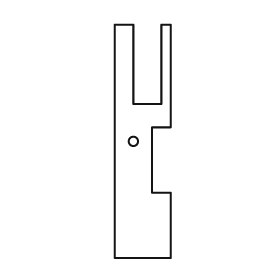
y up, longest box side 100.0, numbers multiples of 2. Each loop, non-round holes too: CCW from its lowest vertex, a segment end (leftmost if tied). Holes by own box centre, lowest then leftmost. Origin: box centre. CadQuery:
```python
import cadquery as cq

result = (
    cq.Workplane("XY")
    .moveTo(-12.0, -50.0)
    .lineTo(12.0, -50.0)
    .lineTo(12.0, -22.0)
    .lineTo(4.0, -22.0)
    .lineTo(4.0, 6.0)
    .lineTo(12.0, 6.0)
    .lineTo(12.0, 50.0)
    .lineTo(8.0, 50.0)
    .lineTo(8.0, 16.0)
    .lineTo(-4.0, 16.0)
    .lineTo(-4.0, 50.0)
    .lineTo(-12.0, 50.0)
    .close()
    .moveTo(-4.0, 0.0)
    .circle(2.0)
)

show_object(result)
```